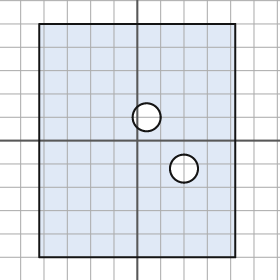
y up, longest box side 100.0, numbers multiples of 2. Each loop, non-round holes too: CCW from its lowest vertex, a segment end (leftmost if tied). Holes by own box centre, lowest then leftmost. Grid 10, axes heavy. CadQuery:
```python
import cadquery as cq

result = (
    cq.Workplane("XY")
    .moveTo(-42.0, -50.0)
    .lineTo(42.0, -50.0)
    .lineTo(42.0, 50.0)
    .lineTo(-42.0, 50.0)
    .close()
    .moveTo(20.0, -12.0)
    .circle(6.0)
    .moveTo(4.0, 10.0)
    .circle(6.0)
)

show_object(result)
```